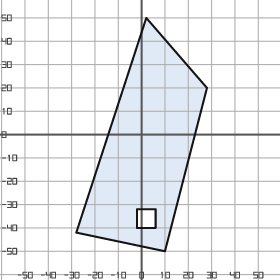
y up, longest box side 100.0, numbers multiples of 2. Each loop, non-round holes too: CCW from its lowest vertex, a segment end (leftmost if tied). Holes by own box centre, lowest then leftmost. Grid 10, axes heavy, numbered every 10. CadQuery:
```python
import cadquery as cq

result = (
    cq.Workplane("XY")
    .moveTo(10.0, -50.0)
    .lineTo(28.0, 20.0)
    .lineTo(2.0, 50.0)
    .lineTo(-28.0, -42.0)
    .close()
    .moveTo(-2.0, -40.0)
    .lineTo(6.0, -40.0)
    .lineTo(6.0, -32.0)
    .lineTo(-2.0, -32.0)
    .close()
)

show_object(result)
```